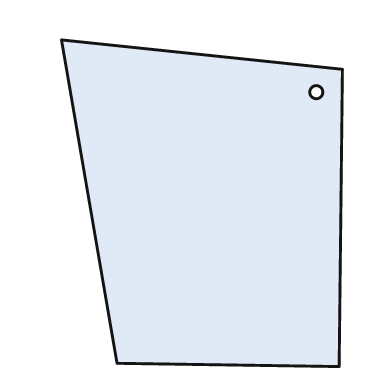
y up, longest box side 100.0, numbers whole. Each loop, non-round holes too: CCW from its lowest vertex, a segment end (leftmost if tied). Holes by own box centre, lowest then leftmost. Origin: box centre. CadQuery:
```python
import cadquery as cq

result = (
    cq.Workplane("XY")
    .moveTo(42.0, -50.0)
    .lineTo(43.0, 41.0)
    .lineTo(-43.0, 50.0)
    .lineTo(-26.0, -49.0)
    .close()
    .moveTo(35.0, 34.0)
    .circle(2.0)
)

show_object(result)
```